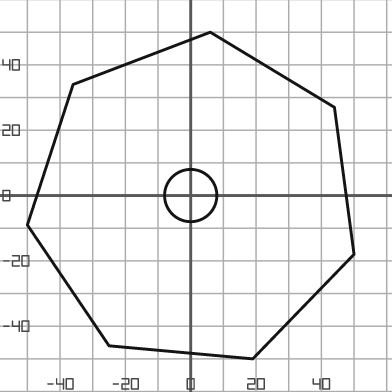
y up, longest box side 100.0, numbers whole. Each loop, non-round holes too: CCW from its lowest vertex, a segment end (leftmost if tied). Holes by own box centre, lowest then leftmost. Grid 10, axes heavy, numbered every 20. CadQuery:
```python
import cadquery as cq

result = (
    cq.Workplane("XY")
    .moveTo(19.0, -50.0)
    .lineTo(50.0, -18.0)
    .lineTo(44.0, 27.0)
    .lineTo(6.0, 50.0)
    .lineTo(-36.0, 34.0)
    .lineTo(-50.0, -9.0)
    .lineTo(-25.0, -46.0)
    .close()
    .moveTo(0.0, 0.0)
    .circle(8.0)
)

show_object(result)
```